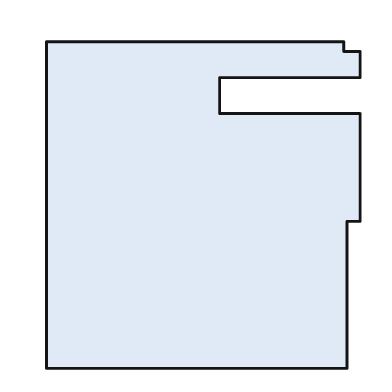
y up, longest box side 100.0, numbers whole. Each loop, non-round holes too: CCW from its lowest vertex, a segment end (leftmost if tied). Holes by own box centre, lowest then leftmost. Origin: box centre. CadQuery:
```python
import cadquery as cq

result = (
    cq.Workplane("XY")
    .moveTo(-48.0, -50.0)
    .lineTo(44.0, -50.0)
    .lineTo(44.0, -5.0)
    .lineTo(48.0, -5.0)
    .lineTo(48.0, 28.0)
    .lineTo(5.0, 28.0)
    .lineTo(5.0, 39.0)
    .lineTo(48.0, 39.0)
    .lineTo(48.0, 47.0)
    .lineTo(43.0, 47.0)
    .lineTo(43.0, 50.0)
    .lineTo(-48.0, 50.0)
    .close()
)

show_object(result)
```